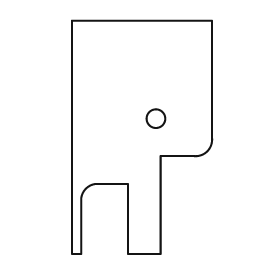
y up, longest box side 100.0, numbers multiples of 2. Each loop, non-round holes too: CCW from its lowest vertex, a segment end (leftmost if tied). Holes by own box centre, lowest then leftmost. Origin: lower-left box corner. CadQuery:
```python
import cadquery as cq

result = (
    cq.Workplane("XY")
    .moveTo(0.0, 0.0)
    .lineTo(4.0, 0.0)
    .lineTo(4.0, 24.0)
    .threePointArc((6.0, 28.0), (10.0, 30.0))
    .lineTo(24.0, 30.0)
    .lineTo(24.0, 0.0)
    .lineTo(38.0, 0.0)
    .lineTo(38.0, 42.0)
    .lineTo(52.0, 42.0)
    .threePointArc((58.0, 44.0), (60.0, 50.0))
    .lineTo(60.0, 100.0)
    .lineTo(0.0, 100.0)
    .close()
    .moveTo(36.0, 58.0)
    .circle(4.0)
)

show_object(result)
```